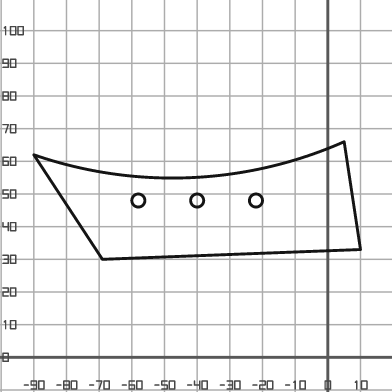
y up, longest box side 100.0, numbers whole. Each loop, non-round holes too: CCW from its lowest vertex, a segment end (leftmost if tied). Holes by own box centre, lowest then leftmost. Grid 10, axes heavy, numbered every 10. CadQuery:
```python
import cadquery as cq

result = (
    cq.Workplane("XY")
    .moveTo(-69.0, 30.0)
    .lineTo(10.0, 33.0)
    .lineTo(5.0, 66.0)
    .threePointArc((-42.0, 55.0), (-90.0, 62.0))
    .close()
    .moveTo(-58.0, 48.0)
    .circle(2.0)
    .moveTo(-40.0, 48.0)
    .circle(2.0)
    .moveTo(-22.0, 48.0)
    .circle(2.0)
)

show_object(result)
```